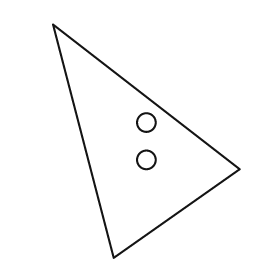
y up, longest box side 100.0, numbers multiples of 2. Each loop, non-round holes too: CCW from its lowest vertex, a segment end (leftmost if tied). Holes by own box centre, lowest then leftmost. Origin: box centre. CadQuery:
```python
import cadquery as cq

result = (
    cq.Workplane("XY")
    .moveTo(-14.0, -50.0)
    .lineTo(40.0, -12.0)
    .lineTo(-40.0, 50.0)
    .close()
    .moveTo(0.0, -8.0)
    .circle(4.0)
    .moveTo(0.0, 8.0)
    .circle(4.0)
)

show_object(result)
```